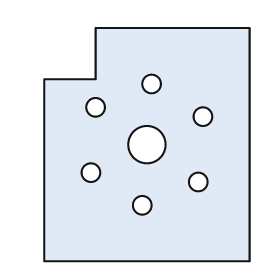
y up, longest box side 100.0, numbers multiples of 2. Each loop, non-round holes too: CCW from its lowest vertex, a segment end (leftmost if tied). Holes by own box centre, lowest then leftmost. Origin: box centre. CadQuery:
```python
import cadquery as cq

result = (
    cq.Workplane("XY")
    .moveTo(-44.0, -50.0)
    .lineTo(44.0, -50.0)
    .lineTo(44.0, 50.0)
    .lineTo(-22.0, 50.0)
    .lineTo(-22.0, 28.0)
    .lineTo(-44.0, 28.0)
    .close()
    .moveTo(-2.0, -26.0)
    .circle(4.0)
    .moveTo(22.0, -16.0)
    .circle(4.0)
    .moveTo(-24.0, -12.0)
    .circle(4.0)
    .moveTo(0.0, 0.0)
    .circle(8.0)
    .moveTo(24.0, 12.0)
    .circle(4.0)
    .moveTo(-22.0, 16.0)
    .circle(4.0)
    .moveTo(2.0, 26.0)
    .circle(4.0)
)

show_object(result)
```